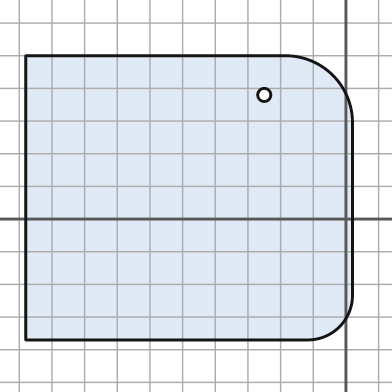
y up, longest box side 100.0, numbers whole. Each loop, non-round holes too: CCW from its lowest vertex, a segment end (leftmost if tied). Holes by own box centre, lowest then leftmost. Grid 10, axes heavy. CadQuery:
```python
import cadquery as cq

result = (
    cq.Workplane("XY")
    .moveTo(-98.0, -37.0)
    .lineTo(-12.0, -37.0)
    .threePointArc((-2.0, -33.0), (2.0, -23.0))
    .lineTo(2.0, 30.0)
    .threePointArc((-4.0, 44.0), (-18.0, 50.0))
    .lineTo(-98.0, 50.0)
    .close()
    .moveTo(-25.0, 38.0)
    .circle(2.0)
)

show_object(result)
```